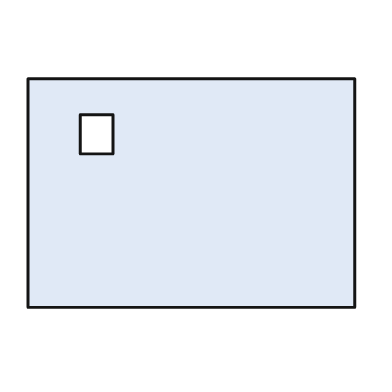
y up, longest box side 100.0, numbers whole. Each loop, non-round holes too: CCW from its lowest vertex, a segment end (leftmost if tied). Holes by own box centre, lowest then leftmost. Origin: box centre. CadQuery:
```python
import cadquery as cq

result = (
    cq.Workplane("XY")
    .moveTo(-50.0, -35.0)
    .lineTo(50.0, -35.0)
    .lineTo(50.0, 35.0)
    .lineTo(-50.0, 35.0)
    .close()
    .moveTo(-34.0, 12.0)
    .lineTo(-24.0, 12.0)
    .lineTo(-24.0, 24.0)
    .lineTo(-34.0, 24.0)
    .close()
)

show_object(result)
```